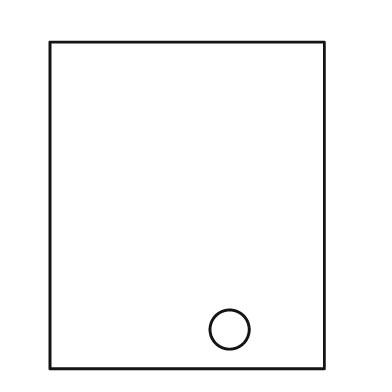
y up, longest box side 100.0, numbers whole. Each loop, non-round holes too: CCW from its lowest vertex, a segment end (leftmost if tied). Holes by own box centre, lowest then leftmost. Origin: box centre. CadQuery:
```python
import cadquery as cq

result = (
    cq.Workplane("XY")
    .moveTo(-42.0, -50.0)
    .lineTo(42.0, -50.0)
    .lineTo(42.0, 50.0)
    .lineTo(-42.0, 50.0)
    .close()
    .moveTo(13.0, -38.0)
    .circle(6.0)
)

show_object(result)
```